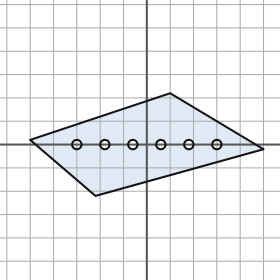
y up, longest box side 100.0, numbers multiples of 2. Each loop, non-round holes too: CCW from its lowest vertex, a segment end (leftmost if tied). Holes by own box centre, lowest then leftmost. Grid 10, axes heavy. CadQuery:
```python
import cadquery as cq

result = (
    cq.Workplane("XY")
    .moveTo(-22.0, -22.0)
    .lineTo(50.0, -2.0)
    .lineTo(10.0, 22.0)
    .lineTo(-50.0, 2.0)
    .close()
    .moveTo(-30.0, 0.0)
    .circle(2.0)
    .moveTo(-18.0, 0.0)
    .circle(2.0)
    .moveTo(-6.0, 0.0)
    .circle(2.0)
    .moveTo(6.0, 0.0)
    .circle(2.0)
    .moveTo(18.0, 0.0)
    .circle(2.0)
    .moveTo(30.0, 0.0)
    .circle(2.0)
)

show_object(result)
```